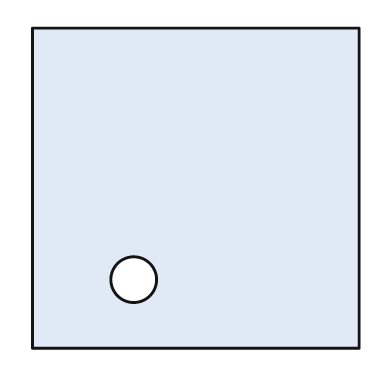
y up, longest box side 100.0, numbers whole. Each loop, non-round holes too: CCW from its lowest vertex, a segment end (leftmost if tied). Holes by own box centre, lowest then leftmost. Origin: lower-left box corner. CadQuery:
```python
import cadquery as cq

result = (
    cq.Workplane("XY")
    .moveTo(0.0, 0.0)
    .lineTo(100.0, 0.0)
    .lineTo(100.0, 98.0)
    .lineTo(0.0, 98.0)
    .close()
    .moveTo(31.0, 21.0)
    .circle(7.0)
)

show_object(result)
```